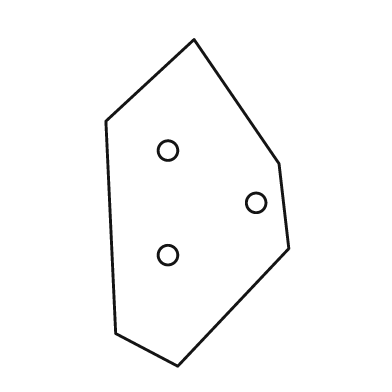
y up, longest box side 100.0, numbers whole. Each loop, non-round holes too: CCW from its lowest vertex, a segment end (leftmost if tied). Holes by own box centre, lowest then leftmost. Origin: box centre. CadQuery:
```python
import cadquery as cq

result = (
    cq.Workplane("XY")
    .moveTo(-6.0, -50.0)
    .lineTo(28.0, -14.0)
    .lineTo(25.0, 12.0)
    .lineTo(-1.0, 50.0)
    .lineTo(-28.0, 25.0)
    .lineTo(-25.0, -40.0)
    .close()
    .moveTo(-9.0, -16.0)
    .circle(3.0)
    .moveTo(18.0, 0.0)
    .circle(3.0)
    .moveTo(-9.0, 16.0)
    .circle(3.0)
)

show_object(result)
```